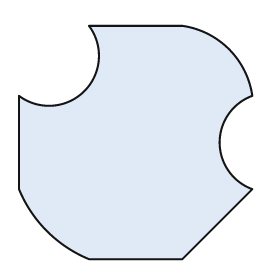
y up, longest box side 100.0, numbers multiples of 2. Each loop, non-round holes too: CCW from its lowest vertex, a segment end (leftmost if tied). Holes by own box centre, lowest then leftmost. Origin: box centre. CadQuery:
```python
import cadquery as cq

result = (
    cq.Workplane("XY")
    .moveTo(-20.0, -50.0)
    .lineTo(20.0, -50.0)
    .lineTo(50.0, -20.0)
    .threePointArc((36.0, 0.0), (50.0, 20.0))
    .threePointArc((40.0, 40.0), (20.0, 50.0))
    .lineTo(-20.0, 50.0)
    .threePointArc((-22.0, 22.0), (-50.0, 20.0))
    .lineTo(-50.0, -20.0)
    .threePointArc((-38.0, -38.0), (-20.0, -50.0))
    .close()
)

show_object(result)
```